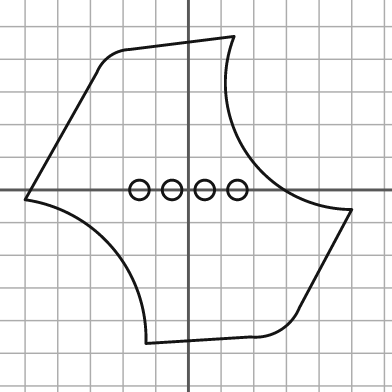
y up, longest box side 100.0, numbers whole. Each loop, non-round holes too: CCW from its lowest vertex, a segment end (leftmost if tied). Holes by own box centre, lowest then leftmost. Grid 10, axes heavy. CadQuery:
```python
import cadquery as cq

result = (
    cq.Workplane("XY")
    .moveTo(-13.0, -47.0)
    .lineTo(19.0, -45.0)
    .threePointArc((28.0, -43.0), (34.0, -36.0))
    .lineTo(50.0, -6.0)
    .threePointArc((18.0, 11.0), (14.0, 47.0))
    .lineTo(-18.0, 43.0)
    .threePointArc((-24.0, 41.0), (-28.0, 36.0))
    .lineTo(-50.0, -3.0)
    .threePointArc((-23.0, -18.0), (-13.0, -47.0))
    .close()
    .moveTo(-15.0, 0.0)
    .circle(3.0)
    .moveTo(-5.0, 0.0)
    .circle(3.0)
    .moveTo(5.0, 0.0)
    .circle(3.0)
    .moveTo(15.0, 0.0)
    .circle(3.0)
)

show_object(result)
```